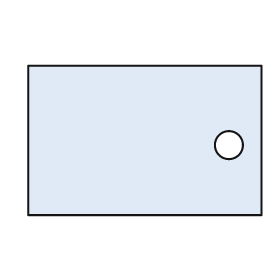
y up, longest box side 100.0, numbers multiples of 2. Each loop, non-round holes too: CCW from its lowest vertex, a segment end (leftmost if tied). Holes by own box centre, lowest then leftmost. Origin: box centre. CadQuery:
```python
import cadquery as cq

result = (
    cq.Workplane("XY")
    .moveTo(-50.0, -32.0)
    .lineTo(50.0, -32.0)
    .lineTo(50.0, 32.0)
    .lineTo(-50.0, 32.0)
    .close()
    .moveTo(36.0, -2.0)
    .circle(6.0)
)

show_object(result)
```